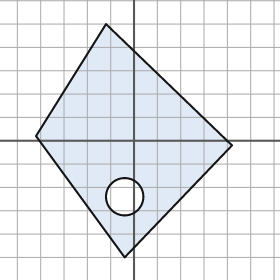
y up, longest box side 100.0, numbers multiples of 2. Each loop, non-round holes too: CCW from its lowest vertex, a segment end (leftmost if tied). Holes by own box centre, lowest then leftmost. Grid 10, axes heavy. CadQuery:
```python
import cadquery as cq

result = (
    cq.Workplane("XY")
    .moveTo(-4.0, -50.0)
    .lineTo(42.0, -2.0)
    .lineTo(-12.0, 50.0)
    .lineTo(-42.0, 2.0)
    .close()
    .moveTo(-4.0, -24.0)
    .circle(8.0)
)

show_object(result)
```